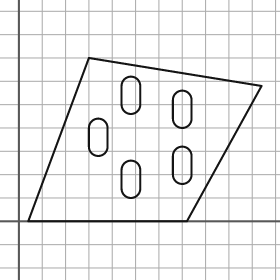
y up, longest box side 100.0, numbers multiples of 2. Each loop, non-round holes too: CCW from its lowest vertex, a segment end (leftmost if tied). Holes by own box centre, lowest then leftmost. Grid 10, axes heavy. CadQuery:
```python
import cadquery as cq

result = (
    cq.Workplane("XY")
    .moveTo(4.0, 0.0)
    .lineTo(72.0, 0.0)
    .lineTo(104.0, 58.0)
    .lineTo(30.0, 70.0)
    .close()
    .moveTo(44.0, 14.0)
    .threePointArc((48.0, 10.0), (52.0, 14.0))
    .lineTo(52.0, 22.0)
    .threePointArc((48.0, 26.0), (44.0, 22.0))
    .close()
    .moveTo(66.0, 20.0)
    .threePointArc((70.0, 16.0), (74.0, 20.0))
    .lineTo(74.0, 28.0)
    .threePointArc((70.0, 32.0), (66.0, 28.0))
    .close()
    .moveTo(30.0, 32.0)
    .threePointArc((34.0, 28.0), (38.0, 32.0))
    .lineTo(38.0, 40.0)
    .threePointArc((34.0, 44.0), (30.0, 40.0))
    .close()
    .moveTo(66.0, 44.0)
    .threePointArc((70.0, 40.0), (74.0, 44.0))
    .lineTo(74.0, 52.0)
    .threePointArc((70.0, 56.0), (66.0, 52.0))
    .close()
    .moveTo(44.0, 50.0)
    .threePointArc((48.0, 46.0), (52.0, 50.0))
    .lineTo(52.0, 58.0)
    .threePointArc((48.0, 62.0), (44.0, 58.0))
    .close()
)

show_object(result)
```